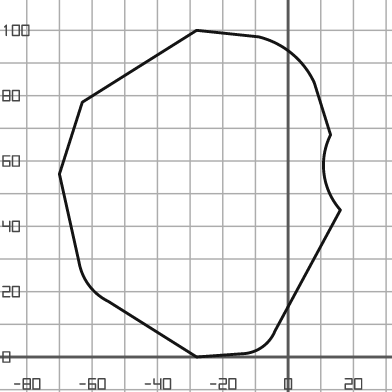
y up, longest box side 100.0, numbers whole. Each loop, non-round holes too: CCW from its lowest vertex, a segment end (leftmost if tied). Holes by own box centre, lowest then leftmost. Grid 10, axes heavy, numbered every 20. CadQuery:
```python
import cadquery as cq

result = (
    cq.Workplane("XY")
    .moveTo(-28.0, 0.0)
    .lineTo(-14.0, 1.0)
    .threePointArc((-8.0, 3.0), (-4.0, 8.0))
    .lineTo(16.0, 45.0)
    .threePointArc((11.0, 56.0), (13.0, 68.0))
    .lineTo(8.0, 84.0)
    .threePointArc((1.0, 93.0), (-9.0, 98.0))
    .lineTo(-28.0, 100.0)
    .lineTo(-63.0, 78.0)
    .lineTo(-70.0, 56.0)
    .lineTo(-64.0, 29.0)
    .threePointArc((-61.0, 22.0), (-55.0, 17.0))
    .close()
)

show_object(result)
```